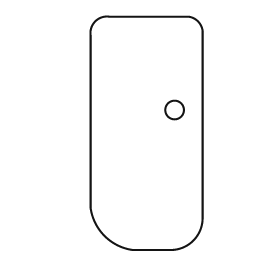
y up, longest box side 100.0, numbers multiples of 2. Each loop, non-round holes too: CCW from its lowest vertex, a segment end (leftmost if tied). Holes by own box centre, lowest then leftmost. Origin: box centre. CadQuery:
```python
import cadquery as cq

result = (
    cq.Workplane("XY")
    .moveTo(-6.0, -50.0)
    .lineTo(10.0, -50.0)
    .threePointArc((20.0, -46.0), (24.0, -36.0))
    .lineTo(24.0, 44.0)
    .threePointArc((22.0, 48.0), (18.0, 50.0))
    .lineTo(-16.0, 50.0)
    .threePointArc((-22.0, 48.0), (-24.0, 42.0))
    .lineTo(-24.0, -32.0)
    .threePointArc((-18.0, -44.0), (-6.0, -50.0))
    .close()
    .moveTo(12.0, 10.0)
    .circle(4.0)
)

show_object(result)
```